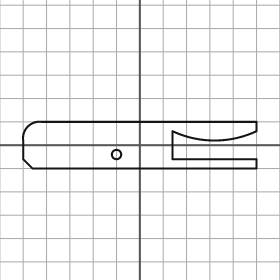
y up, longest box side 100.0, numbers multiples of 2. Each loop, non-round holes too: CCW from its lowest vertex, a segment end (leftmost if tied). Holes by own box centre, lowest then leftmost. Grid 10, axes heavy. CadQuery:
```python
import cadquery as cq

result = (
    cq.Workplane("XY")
    .moveTo(-46.0, -10.0)
    .lineTo(50.0, -10.0)
    .lineTo(50.0, -6.0)
    .lineTo(14.0, -6.0)
    .lineTo(14.0, 6.0)
    .threePointArc((32.0, 2.0), (50.0, 6.0))
    .lineTo(50.0, 10.0)
    .lineTo(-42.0, 10.0)
    .threePointArc((-48.0, 8.0), (-50.0, 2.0))
    .lineTo(-50.0, -6.0)
    .close()
    .moveTo(-10.0, -4.0)
    .circle(2.0)
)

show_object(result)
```